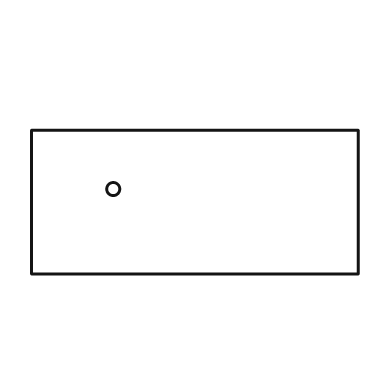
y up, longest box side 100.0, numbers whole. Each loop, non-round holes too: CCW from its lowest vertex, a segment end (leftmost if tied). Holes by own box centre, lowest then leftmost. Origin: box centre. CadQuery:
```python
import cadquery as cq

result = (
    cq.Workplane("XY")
    .moveTo(-50.0, -22.0)
    .lineTo(50.0, -22.0)
    .lineTo(50.0, 22.0)
    .lineTo(-50.0, 22.0)
    .close()
    .moveTo(-25.0, 4.0)
    .circle(2.0)
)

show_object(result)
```